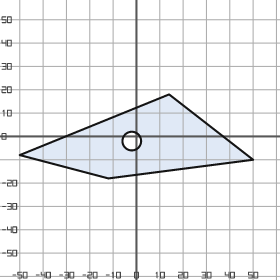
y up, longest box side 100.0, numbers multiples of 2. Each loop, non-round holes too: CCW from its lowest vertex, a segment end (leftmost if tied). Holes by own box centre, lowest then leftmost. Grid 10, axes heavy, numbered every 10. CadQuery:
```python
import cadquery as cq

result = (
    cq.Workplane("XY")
    .moveTo(-12.0, -18.0)
    .lineTo(50.0, -10.0)
    .lineTo(14.0, 18.0)
    .lineTo(-50.0, -8.0)
    .close()
    .moveTo(-2.0, -2.0)
    .circle(4.0)
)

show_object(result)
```